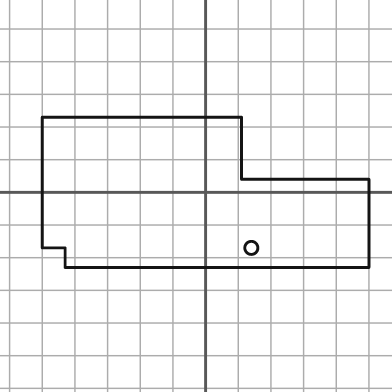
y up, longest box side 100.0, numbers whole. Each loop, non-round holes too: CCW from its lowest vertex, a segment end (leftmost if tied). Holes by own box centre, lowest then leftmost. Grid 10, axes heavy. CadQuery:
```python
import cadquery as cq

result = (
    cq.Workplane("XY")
    .moveTo(-43.0, -23.0)
    .lineTo(50.0, -23.0)
    .lineTo(50.0, 4.0)
    .lineTo(11.0, 4.0)
    .lineTo(11.0, 23.0)
    .lineTo(-50.0, 23.0)
    .lineTo(-50.0, -17.0)
    .lineTo(-43.0, -17.0)
    .close()
    .moveTo(14.0, -17.0)
    .circle(2.0)
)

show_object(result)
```